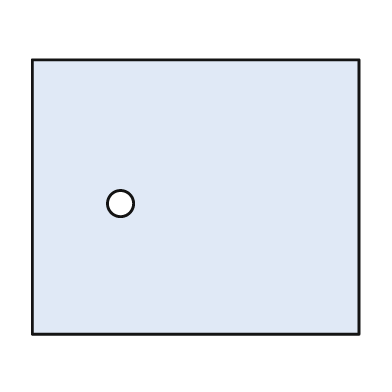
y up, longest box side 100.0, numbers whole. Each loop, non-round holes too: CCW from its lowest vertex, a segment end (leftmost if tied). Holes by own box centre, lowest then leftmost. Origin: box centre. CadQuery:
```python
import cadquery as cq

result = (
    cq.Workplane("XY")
    .moveTo(-50.0, -42.0)
    .lineTo(50.0, -42.0)
    .lineTo(50.0, 42.0)
    .lineTo(-50.0, 42.0)
    .close()
    .moveTo(-23.0, -2.0)
    .circle(4.0)
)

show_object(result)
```